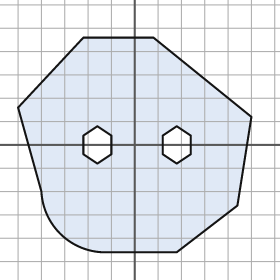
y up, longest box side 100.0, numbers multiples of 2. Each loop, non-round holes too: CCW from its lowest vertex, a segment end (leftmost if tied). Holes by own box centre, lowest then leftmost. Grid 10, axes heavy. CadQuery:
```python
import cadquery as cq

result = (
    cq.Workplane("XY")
    .moveTo(-14.0, -46.0)
    .lineTo(18.0, -46.0)
    .lineTo(44.0, -26.0)
    .lineTo(50.0, 12.0)
    .lineTo(8.0, 46.0)
    .lineTo(-22.0, 46.0)
    .lineTo(-50.0, 16.0)
    .lineTo(-40.0, -20.0)
    .threePointArc((-32.0, -38.0), (-14.0, -46.0))
    .close()
    .moveTo(-16.0, -8.0)
    .lineTo(-10.0, -4.0)
    .lineTo(-10.0, 4.0)
    .lineTo(-16.0, 8.0)
    .lineTo(-22.0, 4.0)
    .lineTo(-22.0, -4.0)
    .close()
    .moveTo(18.0, -8.0)
    .lineTo(24.0, -4.0)
    .lineTo(24.0, 4.0)
    .lineTo(18.0, 8.0)
    .lineTo(12.0, 4.0)
    .lineTo(12.0, -4.0)
    .close()
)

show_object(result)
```